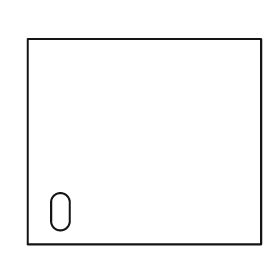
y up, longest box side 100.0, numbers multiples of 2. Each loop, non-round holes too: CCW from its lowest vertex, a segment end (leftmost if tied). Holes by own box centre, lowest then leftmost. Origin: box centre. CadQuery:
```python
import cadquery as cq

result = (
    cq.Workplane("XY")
    .moveTo(-50.0, -44.0)
    .lineTo(50.0, -44.0)
    .lineTo(50.0, 44.0)
    .lineTo(-50.0, 44.0)
    .close()
    .moveTo(-40.0, -34.0)
    .threePointArc((-36.0, -38.0), (-32.0, -34.0))
    .lineTo(-32.0, -26.0)
    .threePointArc((-36.0, -22.0), (-40.0, -26.0))
    .close()
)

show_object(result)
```